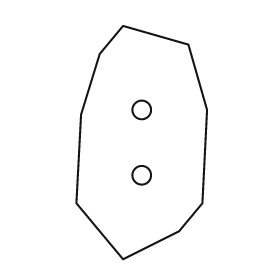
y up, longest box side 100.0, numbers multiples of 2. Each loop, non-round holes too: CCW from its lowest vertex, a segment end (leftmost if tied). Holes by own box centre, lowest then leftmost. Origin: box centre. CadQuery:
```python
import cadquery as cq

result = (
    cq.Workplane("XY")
    .moveTo(-8.0, -50.0)
    .lineTo(16.0, -38.0)
    .lineTo(26.0, -26.0)
    .lineTo(28.0, 14.0)
    .lineTo(20.0, 42.0)
    .lineTo(-8.0, 50.0)
    .lineTo(-18.0, 38.0)
    .lineTo(-26.0, 12.0)
    .lineTo(-28.0, -26.0)
    .close()
    .moveTo(0.0, -14.0)
    .circle(4.0)
    .moveTo(0.0, 14.0)
    .circle(4.0)
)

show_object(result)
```